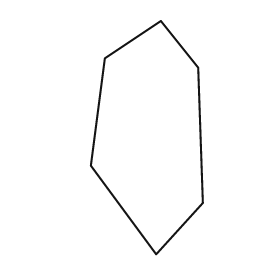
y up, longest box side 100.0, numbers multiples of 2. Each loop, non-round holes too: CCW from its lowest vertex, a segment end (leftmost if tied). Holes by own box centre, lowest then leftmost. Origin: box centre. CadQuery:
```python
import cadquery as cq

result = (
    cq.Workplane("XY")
    .moveTo(4.0, -50.0)
    .lineTo(24.0, -28.0)
    .lineTo(22.0, 30.0)
    .lineTo(6.0, 50.0)
    .lineTo(-18.0, 34.0)
    .lineTo(-24.0, -12.0)
    .close()
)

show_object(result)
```